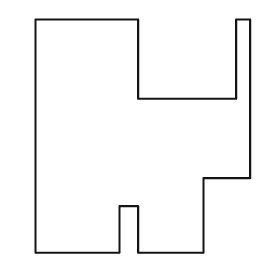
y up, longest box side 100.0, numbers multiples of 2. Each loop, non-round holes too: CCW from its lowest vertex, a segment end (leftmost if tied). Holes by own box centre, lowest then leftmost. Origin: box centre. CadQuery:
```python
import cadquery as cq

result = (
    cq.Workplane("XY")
    .moveTo(-46.0, -50.0)
    .lineTo(-10.0, -50.0)
    .lineTo(-10.0, -30.0)
    .lineTo(-2.0, -30.0)
    .lineTo(-2.0, -50.0)
    .lineTo(26.0, -50.0)
    .lineTo(26.0, -18.0)
    .lineTo(46.0, -18.0)
    .lineTo(46.0, 50.0)
    .lineTo(40.0, 50.0)
    .lineTo(40.0, 16.0)
    .lineTo(-2.0, 16.0)
    .lineTo(-2.0, 50.0)
    .lineTo(-46.0, 50.0)
    .close()
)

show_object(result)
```